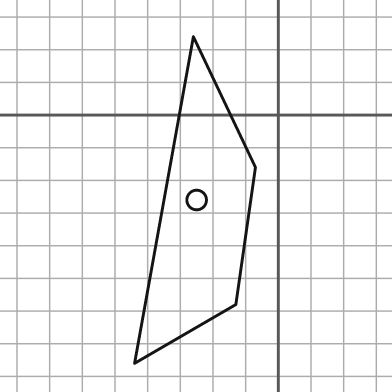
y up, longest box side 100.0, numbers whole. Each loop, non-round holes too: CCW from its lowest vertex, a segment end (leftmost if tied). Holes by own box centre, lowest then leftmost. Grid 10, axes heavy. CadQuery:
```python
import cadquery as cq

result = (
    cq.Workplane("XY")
    .moveTo(-44.0, -76.0)
    .lineTo(-13.0, -58.0)
    .lineTo(-7.0, -16.0)
    .lineTo(-26.0, 24.0)
    .close()
    .moveTo(-25.0, -26.0)
    .circle(3.0)
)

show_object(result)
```